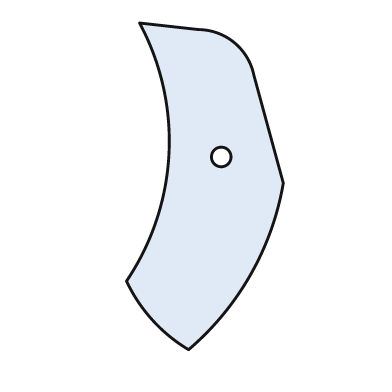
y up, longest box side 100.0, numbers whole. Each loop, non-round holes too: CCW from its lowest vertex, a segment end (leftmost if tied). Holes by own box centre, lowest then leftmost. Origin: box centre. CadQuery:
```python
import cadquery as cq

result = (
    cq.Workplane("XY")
    .moveTo(-5.0, -50.0)
    .threePointArc((14.0, -27.0), (24.0, 1.0))
    .lineTo(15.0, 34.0)
    .threePointArc((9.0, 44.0), (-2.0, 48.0))
    .lineTo(-20.0, 50.0)
    .threePointArc((-11.0, 10.0), (-24.0, -29.0))
    .threePointArc((-16.0, -41.0), (-5.0, -50.0))
    .close()
    .moveTo(5.0, 9.0)
    .circle(3.0)
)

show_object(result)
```